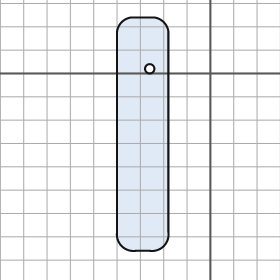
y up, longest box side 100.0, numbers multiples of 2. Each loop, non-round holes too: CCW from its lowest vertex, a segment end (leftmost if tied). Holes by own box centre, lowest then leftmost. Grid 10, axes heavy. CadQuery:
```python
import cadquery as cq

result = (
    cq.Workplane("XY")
    .moveTo(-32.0, -76.0)
    .lineTo(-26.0, -76.0)
    .threePointArc((-20.0, -74.0), (-18.0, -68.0))
    .lineTo(-18.0, 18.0)
    .threePointArc((-20.0, 22.0), (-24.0, 24.0))
    .lineTo(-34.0, 24.0)
    .threePointArc((-38.0, 22.0), (-40.0, 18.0))
    .lineTo(-40.0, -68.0)
    .threePointArc((-38.0, -74.0), (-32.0, -76.0))
    .close()
    .moveTo(-26.0, 2.0)
    .circle(2.0)
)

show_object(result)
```